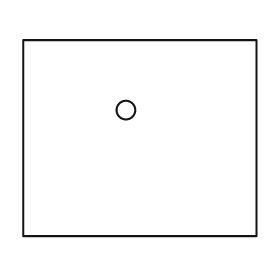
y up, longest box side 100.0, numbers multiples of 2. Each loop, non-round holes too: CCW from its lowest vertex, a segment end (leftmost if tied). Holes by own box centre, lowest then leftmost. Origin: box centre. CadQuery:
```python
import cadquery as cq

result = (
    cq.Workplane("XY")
    .moveTo(-50.0, -42.0)
    .lineTo(50.0, -42.0)
    .lineTo(50.0, 42.0)
    .lineTo(-50.0, 42.0)
    .close()
    .moveTo(-6.0, 12.0)
    .circle(4.0)
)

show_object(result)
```